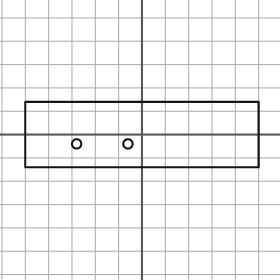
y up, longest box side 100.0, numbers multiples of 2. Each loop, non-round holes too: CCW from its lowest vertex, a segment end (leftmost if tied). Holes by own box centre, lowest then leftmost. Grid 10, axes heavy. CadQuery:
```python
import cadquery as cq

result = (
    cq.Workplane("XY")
    .moveTo(-50.0, -14.0)
    .lineTo(50.0, -14.0)
    .lineTo(50.0, 14.0)
    .lineTo(-50.0, 14.0)
    .close()
    .moveTo(-28.0, -4.0)
    .circle(2.0)
    .moveTo(-6.0, -4.0)
    .circle(2.0)
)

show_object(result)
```